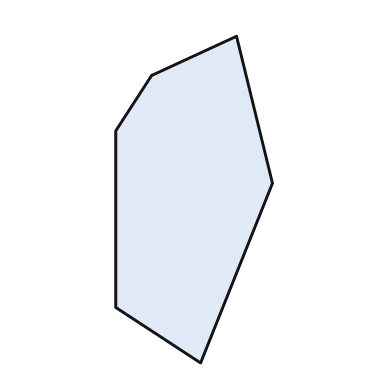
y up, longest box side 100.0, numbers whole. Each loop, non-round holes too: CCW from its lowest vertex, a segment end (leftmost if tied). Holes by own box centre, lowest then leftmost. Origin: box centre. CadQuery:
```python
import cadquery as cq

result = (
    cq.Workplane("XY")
    .moveTo(2.0, -50.0)
    .lineTo(24.0, 5.0)
    .lineTo(13.0, 50.0)
    .lineTo(-13.0, 38.0)
    .lineTo(-24.0, 21.0)
    .lineTo(-24.0, -33.0)
    .close()
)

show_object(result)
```